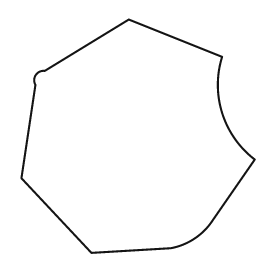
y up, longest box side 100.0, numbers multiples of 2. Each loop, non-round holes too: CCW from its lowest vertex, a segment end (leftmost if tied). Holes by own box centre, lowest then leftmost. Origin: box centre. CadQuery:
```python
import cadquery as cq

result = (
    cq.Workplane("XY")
    .moveTo(-20.0, -50.0)
    .lineTo(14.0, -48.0)
    .threePointArc((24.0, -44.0), (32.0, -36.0))
    .lineTo(50.0, -10.0)
    .threePointArc((36.0, 10.0), (36.0, 34.0))
    .lineTo(-4.0, 50.0)
    .lineTo(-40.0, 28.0)
    .threePointArc((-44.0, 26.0), (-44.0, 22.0))
    .lineTo(-50.0, -18.0)
    .close()
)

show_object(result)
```